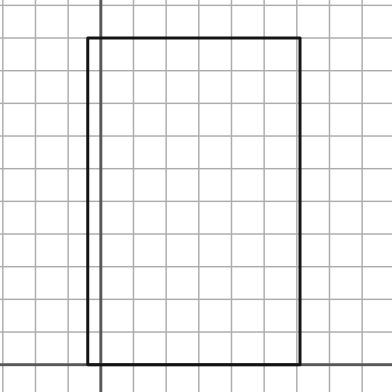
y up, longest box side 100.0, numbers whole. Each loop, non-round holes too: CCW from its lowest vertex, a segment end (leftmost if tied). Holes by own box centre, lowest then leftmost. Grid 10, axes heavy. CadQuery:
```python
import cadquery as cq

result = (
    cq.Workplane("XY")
    .moveTo(-4.0, 0.0)
    .lineTo(61.0, 0.0)
    .lineTo(61.0, 100.0)
    .lineTo(-4.0, 100.0)
    .close()
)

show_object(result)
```